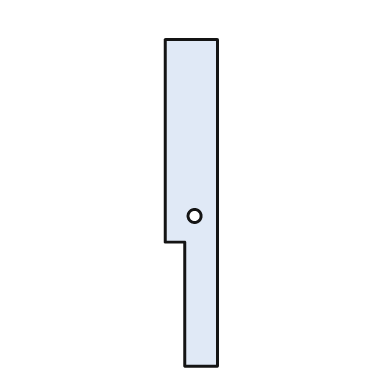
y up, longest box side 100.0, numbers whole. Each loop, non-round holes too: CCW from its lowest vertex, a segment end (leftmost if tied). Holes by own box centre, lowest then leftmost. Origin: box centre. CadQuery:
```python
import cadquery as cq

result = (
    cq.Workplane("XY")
    .moveTo(-2.0, -50.0)
    .lineTo(8.0, -50.0)
    .lineTo(8.0, 50.0)
    .lineTo(-8.0, 50.0)
    .lineTo(-8.0, -12.0)
    .lineTo(-2.0, -12.0)
    .close()
    .moveTo(1.0, -4.0)
    .circle(2.0)
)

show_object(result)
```